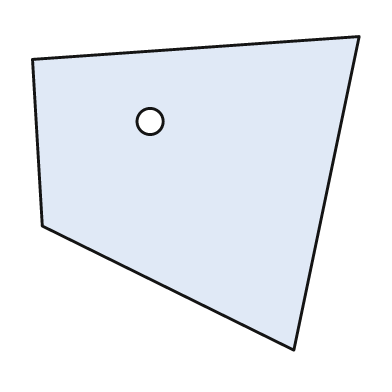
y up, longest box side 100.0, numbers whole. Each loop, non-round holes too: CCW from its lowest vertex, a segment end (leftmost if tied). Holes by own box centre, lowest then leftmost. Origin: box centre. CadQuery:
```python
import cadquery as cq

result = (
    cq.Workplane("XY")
    .moveTo(30.0, -48.0)
    .lineTo(50.0, 48.0)
    .lineTo(-50.0, 41.0)
    .lineTo(-47.0, -10.0)
    .close()
    .moveTo(-14.0, 22.0)
    .circle(4.0)
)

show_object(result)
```